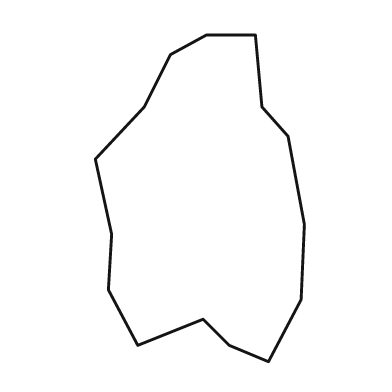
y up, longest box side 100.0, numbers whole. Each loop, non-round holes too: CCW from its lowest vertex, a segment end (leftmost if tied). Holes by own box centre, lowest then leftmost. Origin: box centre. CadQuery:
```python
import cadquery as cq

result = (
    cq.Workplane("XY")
    .moveTo(21.0, -50.0)
    .lineTo(31.0, -31.0)
    .lineTo(32.0, -8.0)
    .lineTo(27.0, 19.0)
    .lineTo(19.0, 28.0)
    .lineTo(17.0, 50.0)
    .lineTo(2.0, 50.0)
    .lineTo(-9.0, 44.0)
    .lineTo(-17.0, 28.0)
    .lineTo(-32.0, 12.0)
    .lineTo(-27.0, -11.0)
    .lineTo(-28.0, -28.0)
    .lineTo(-19.0, -45.0)
    .lineTo(1.0, -37.0)
    .lineTo(9.0, -45.0)
    .close()
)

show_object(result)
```